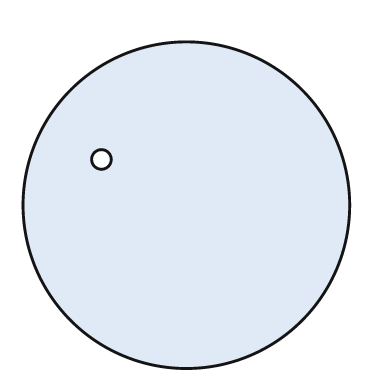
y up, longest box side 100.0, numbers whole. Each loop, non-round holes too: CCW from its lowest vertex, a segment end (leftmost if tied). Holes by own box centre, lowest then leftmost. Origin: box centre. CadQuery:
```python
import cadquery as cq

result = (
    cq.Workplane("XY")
    .moveTo(0.0, 0.0)
    .circle(50.0)
    .moveTo(-26.0, 14.0)
    .circle(3.0)
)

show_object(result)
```